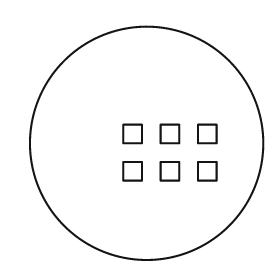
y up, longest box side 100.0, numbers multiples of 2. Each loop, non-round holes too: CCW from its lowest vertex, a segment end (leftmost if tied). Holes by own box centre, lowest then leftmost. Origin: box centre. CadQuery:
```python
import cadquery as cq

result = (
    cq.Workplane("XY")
    .moveTo(0.0, 0.0)
    .circle(50.0)
    .moveTo(-10.0, -16.0)
    .lineTo(-2.0, -16.0)
    .lineTo(-2.0, -8.0)
    .lineTo(-10.0, -8.0)
    .close()
    .moveTo(6.0, -16.0)
    .lineTo(14.0, -16.0)
    .lineTo(14.0, -8.0)
    .lineTo(6.0, -8.0)
    .close()
    .moveTo(22.0, -16.0)
    .lineTo(30.0, -16.0)
    .lineTo(30.0, -8.0)
    .lineTo(22.0, -8.0)
    .close()
    .moveTo(-10.0, 0.0)
    .lineTo(-2.0, 0.0)
    .lineTo(-2.0, 8.0)
    .lineTo(-10.0, 8.0)
    .close()
    .moveTo(6.0, 0.0)
    .lineTo(14.0, 0.0)
    .lineTo(14.0, 8.0)
    .lineTo(6.0, 8.0)
    .close()
    .moveTo(22.0, 0.0)
    .lineTo(30.0, 0.0)
    .lineTo(30.0, 8.0)
    .lineTo(22.0, 8.0)
    .close()
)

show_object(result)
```